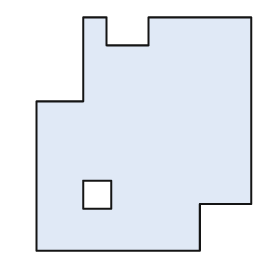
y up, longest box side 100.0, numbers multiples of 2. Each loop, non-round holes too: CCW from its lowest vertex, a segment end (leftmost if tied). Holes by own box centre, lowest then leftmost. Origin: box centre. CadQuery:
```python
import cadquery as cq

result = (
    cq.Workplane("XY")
    .moveTo(-46.0, -50.0)
    .lineTo(24.0, -50.0)
    .lineTo(24.0, -30.0)
    .lineTo(46.0, -30.0)
    .lineTo(46.0, 50.0)
    .lineTo(2.0, 50.0)
    .lineTo(2.0, 38.0)
    .lineTo(-16.0, 38.0)
    .lineTo(-16.0, 50.0)
    .lineTo(-26.0, 50.0)
    .lineTo(-26.0, 14.0)
    .lineTo(-46.0, 14.0)
    .close()
    .moveTo(-26.0, -32.0)
    .lineTo(-14.0, -32.0)
    .lineTo(-14.0, -20.0)
    .lineTo(-26.0, -20.0)
    .close()
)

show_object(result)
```